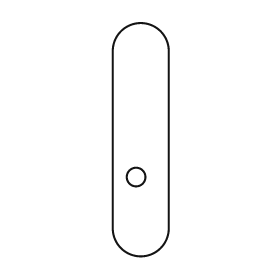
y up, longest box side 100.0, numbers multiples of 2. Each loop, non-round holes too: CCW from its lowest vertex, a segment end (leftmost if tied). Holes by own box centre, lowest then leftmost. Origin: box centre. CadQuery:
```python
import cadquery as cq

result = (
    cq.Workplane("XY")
    .moveTo(-12.0, -38.0)
    .threePointArc((0.0, -50.0), (12.0, -38.0))
    .lineTo(12.0, 38.0)
    .threePointArc((0.0, 50.0), (-12.0, 38.0))
    .close()
    .moveTo(-2.0, -16.0)
    .circle(4.0)
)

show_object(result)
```